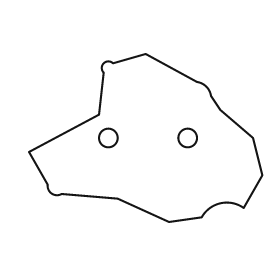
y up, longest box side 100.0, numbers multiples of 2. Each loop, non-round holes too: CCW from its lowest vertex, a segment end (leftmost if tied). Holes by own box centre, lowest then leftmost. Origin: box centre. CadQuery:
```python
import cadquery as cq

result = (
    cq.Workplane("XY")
    .moveTo(10.0, -36.0)
    .lineTo(24.0, -34.0)
    .threePointArc((32.0, -28.0), (42.0, -30.0))
    .lineTo(50.0, -16.0)
    .lineTo(46.0, 0.0)
    .lineTo(32.0, 12.0)
    .lineTo(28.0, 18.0)
    .threePointArc((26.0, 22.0), (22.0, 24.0))
    .lineTo(0.0, 36.0)
    .lineTo(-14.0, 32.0)
    .threePointArc((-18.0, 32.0), (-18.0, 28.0))
    .lineTo(-20.0, 10.0)
    .lineTo(-50.0, -6.0)
    .lineTo(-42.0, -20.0)
    .threePointArc((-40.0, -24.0), (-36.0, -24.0))
    .lineTo(-12.0, -26.0)
    .close()
    .moveTo(-16.0, 0.0)
    .circle(4.0)
    .moveTo(18.0, 0.0)
    .circle(4.0)
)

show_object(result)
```